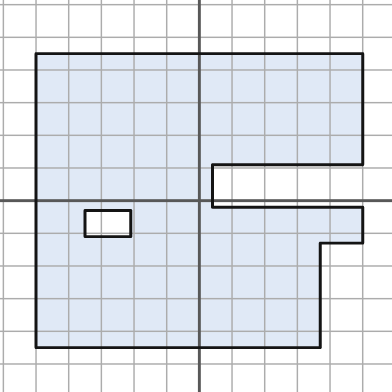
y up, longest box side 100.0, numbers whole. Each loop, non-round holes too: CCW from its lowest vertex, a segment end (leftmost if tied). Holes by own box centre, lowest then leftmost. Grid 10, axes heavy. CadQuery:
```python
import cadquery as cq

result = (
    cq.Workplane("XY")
    .moveTo(-50.0, -45.0)
    .lineTo(37.0, -45.0)
    .lineTo(37.0, -13.0)
    .lineTo(50.0, -13.0)
    .lineTo(50.0, -2.0)
    .lineTo(4.0, -2.0)
    .lineTo(4.0, 11.0)
    .lineTo(50.0, 11.0)
    .lineTo(50.0, 45.0)
    .lineTo(-50.0, 45.0)
    .close()
    .moveTo(-35.0, -11.0)
    .lineTo(-21.0, -11.0)
    .lineTo(-21.0, -3.0)
    .lineTo(-35.0, -3.0)
    .close()
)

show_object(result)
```